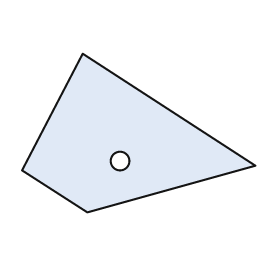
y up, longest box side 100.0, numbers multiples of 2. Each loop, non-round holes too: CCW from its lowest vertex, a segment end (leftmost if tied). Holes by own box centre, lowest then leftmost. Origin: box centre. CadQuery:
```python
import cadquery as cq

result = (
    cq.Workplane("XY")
    .moveTo(-22.0, -34.0)
    .lineTo(50.0, -14.0)
    .lineTo(-24.0, 34.0)
    .lineTo(-50.0, -16.0)
    .close()
    .moveTo(-8.0, -12.0)
    .circle(4.0)
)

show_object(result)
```